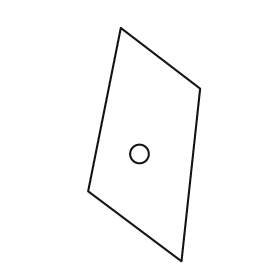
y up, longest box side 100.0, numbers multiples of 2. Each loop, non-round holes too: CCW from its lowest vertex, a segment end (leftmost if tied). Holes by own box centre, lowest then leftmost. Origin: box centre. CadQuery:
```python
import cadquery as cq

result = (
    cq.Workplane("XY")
    .moveTo(16.0, -50.0)
    .lineTo(24.0, 24.0)
    .lineTo(-10.0, 50.0)
    .lineTo(-24.0, -20.0)
    .close()
    .moveTo(-2.0, -4.0)
    .circle(4.0)
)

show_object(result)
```